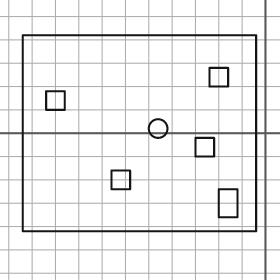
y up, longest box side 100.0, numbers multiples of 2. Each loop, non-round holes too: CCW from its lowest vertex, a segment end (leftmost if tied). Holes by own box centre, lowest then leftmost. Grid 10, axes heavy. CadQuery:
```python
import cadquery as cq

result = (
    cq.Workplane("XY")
    .moveTo(-104.0, -42.0)
    .lineTo(-4.0, -42.0)
    .lineTo(-4.0, 42.0)
    .lineTo(-104.0, 42.0)
    .close()
    .moveTo(-20.0, -36.0)
    .lineTo(-12.0, -36.0)
    .lineTo(-12.0, -24.0)
    .lineTo(-20.0, -24.0)
    .close()
    .moveTo(-66.0, -24.0)
    .lineTo(-58.0, -24.0)
    .lineTo(-58.0, -16.0)
    .lineTo(-66.0, -16.0)
    .close()
    .moveTo(-30.0, -10.0)
    .lineTo(-22.0, -10.0)
    .lineTo(-22.0, -2.0)
    .lineTo(-30.0, -2.0)
    .close()
    .moveTo(-46.0, 2.0)
    .circle(4.0)
    .moveTo(-94.0, 10.0)
    .lineTo(-86.0, 10.0)
    .lineTo(-86.0, 18.0)
    .lineTo(-94.0, 18.0)
    .close()
    .moveTo(-24.0, 20.0)
    .lineTo(-16.0, 20.0)
    .lineTo(-16.0, 28.0)
    .lineTo(-24.0, 28.0)
    .close()
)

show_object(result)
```